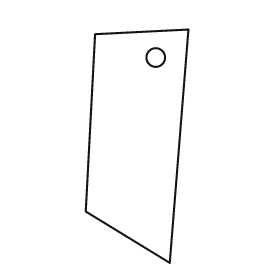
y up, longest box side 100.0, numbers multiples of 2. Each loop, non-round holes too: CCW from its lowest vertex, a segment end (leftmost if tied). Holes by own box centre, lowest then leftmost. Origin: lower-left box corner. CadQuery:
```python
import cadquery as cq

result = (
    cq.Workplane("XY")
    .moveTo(36.0, 0.0)
    .lineTo(44.0, 100.0)
    .lineTo(4.0, 98.0)
    .lineTo(0.0, 22.0)
    .close()
    .moveTo(30.0, 88.0)
    .circle(4.0)
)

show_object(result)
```